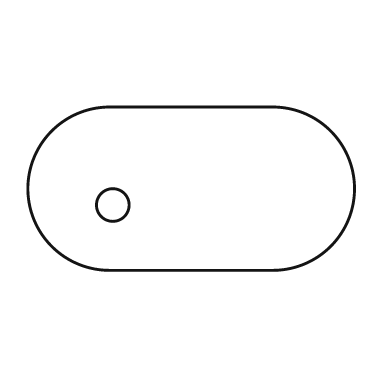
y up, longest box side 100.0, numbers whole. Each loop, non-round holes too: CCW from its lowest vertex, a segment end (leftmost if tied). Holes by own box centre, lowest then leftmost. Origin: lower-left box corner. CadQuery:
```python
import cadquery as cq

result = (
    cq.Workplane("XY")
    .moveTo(25.0, 0.0)
    .lineTo(75.0, 0.0)
    .threePointArc((100.0, 25.0), (75.0, 50.0))
    .lineTo(25.0, 50.0)
    .threePointArc((0.0, 25.0), (25.0, 0.0))
    .close()
    .moveTo(26.0, 20.0)
    .circle(5.0)
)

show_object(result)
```